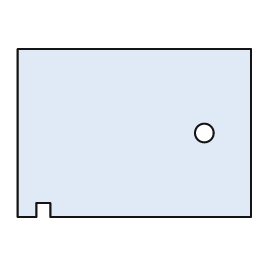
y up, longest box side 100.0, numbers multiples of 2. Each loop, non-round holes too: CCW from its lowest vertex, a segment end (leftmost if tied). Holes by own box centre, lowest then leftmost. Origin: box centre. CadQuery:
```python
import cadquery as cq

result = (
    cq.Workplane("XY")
    .moveTo(-50.0, -36.0)
    .lineTo(-42.0, -36.0)
    .lineTo(-42.0, -30.0)
    .lineTo(-36.0, -30.0)
    .lineTo(-36.0, -36.0)
    .lineTo(50.0, -36.0)
    .lineTo(50.0, 36.0)
    .lineTo(-50.0, 36.0)
    .close()
    .moveTo(30.0, 0.0)
    .circle(4.0)
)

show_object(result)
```